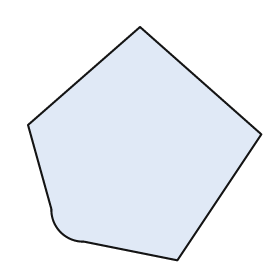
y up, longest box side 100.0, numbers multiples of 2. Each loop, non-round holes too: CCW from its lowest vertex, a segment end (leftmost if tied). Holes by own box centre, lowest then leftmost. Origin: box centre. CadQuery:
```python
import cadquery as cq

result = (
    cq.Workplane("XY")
    .moveTo(14.0, -50.0)
    .lineTo(50.0, 4.0)
    .lineTo(-2.0, 50.0)
    .lineTo(-50.0, 8.0)
    .lineTo(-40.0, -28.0)
    .threePointArc((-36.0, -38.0), (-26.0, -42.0))
    .close()
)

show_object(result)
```